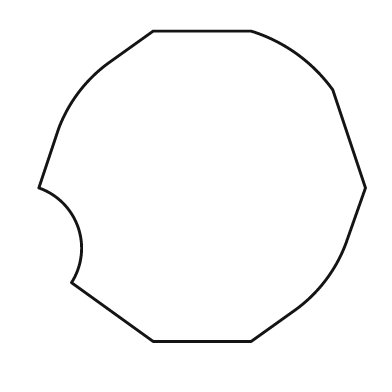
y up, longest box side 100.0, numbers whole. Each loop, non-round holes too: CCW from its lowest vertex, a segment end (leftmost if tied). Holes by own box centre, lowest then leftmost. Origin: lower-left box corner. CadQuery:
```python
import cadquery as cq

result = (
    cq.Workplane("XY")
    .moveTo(35.0, 0.0)
    .lineTo(65.0, 0.0)
    .lineTo(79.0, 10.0)
    .threePointArc((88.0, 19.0), (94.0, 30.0))
    .lineTo(100.0, 47.0)
    .lineTo(90.0, 77.0)
    .threePointArc((79.0, 88.0), (65.0, 95.0))
    .lineTo(35.0, 95.0)
    .lineTo(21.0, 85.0)
    .threePointArc((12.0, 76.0), (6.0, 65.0))
    .lineTo(0.0, 47.0)
    .threePointArc((12.0, 35.0), (10.0, 18.0))
    .close()
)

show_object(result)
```